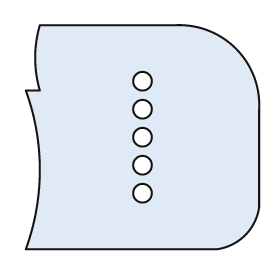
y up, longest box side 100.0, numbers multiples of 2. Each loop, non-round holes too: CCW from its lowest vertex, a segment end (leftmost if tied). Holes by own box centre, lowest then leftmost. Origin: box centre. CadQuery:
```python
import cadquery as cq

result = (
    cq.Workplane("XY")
    .moveTo(-50.0, -48.0)
    .lineTo(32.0, -48.0)
    .threePointArc((44.0, -42.0), (50.0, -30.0))
    .lineTo(50.0, 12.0)
    .threePointArc((40.0, 38.0), (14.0, 48.0))
    .lineTo(-44.0, 48.0)
    .threePointArc((-46.0, 34.0), (-44.0, 20.0))
    .lineTo(-50.0, 20.0)
    .threePointArc((-44.0, -14.0), (-50.0, -48.0))
    .close()
    .moveTo(0.0, -24.0)
    .circle(4.0)
    .moveTo(0.0, -12.0)
    .circle(4.0)
    .moveTo(0.0, 0.0)
    .circle(4.0)
    .moveTo(0.0, 12.0)
    .circle(4.0)
    .moveTo(0.0, 24.0)
    .circle(4.0)
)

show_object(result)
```